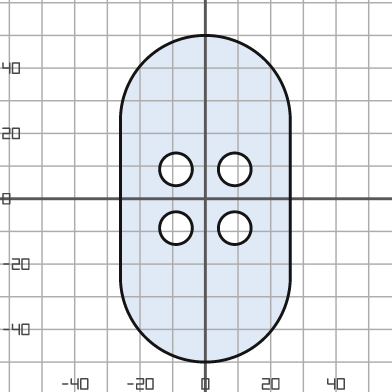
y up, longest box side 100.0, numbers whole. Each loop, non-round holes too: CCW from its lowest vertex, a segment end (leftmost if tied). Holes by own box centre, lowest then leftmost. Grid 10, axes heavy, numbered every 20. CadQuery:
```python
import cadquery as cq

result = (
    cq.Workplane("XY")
    .moveTo(-26.0, -24.0)
    .threePointArc((0.0, -50.0), (26.0, -24.0))
    .lineTo(26.0, 24.0)
    .threePointArc((0.0, 50.0), (-26.0, 24.0))
    .close()
    .moveTo(-9.0, -9.0)
    .circle(5.0)
    .moveTo(9.0, -9.0)
    .circle(5.0)
    .moveTo(-9.0, 9.0)
    .circle(5.0)
    .moveTo(9.0, 9.0)
    .circle(5.0)
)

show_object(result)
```